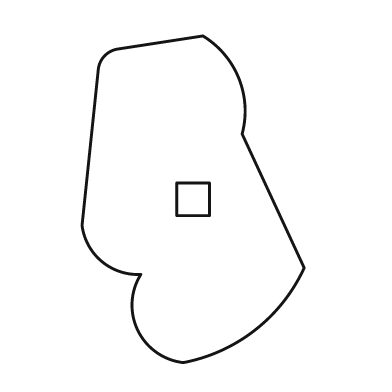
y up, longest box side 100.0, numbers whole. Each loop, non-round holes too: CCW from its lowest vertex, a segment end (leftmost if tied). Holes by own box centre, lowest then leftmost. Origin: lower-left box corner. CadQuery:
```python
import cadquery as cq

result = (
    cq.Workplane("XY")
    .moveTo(31.0, 0.0)
    .threePointArc((53.0, 10.0), (68.0, 29.0))
    .lineTo(49.0, 70.0)
    .threePointArc((48.0, 87.0), (37.0, 100.0))
    .lineTo(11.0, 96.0)
    .threePointArc((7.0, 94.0), (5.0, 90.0))
    .lineTo(0.0, 42.0)
    .threePointArc((6.0, 31.0), (18.0, 27.0))
    .threePointArc((17.0, 10.0), (31.0, 0.0))
    .close()
    .moveTo(29.0, 45.0)
    .lineTo(39.0, 45.0)
    .lineTo(39.0, 55.0)
    .lineTo(29.0, 55.0)
    .close()
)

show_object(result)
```